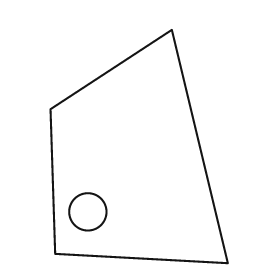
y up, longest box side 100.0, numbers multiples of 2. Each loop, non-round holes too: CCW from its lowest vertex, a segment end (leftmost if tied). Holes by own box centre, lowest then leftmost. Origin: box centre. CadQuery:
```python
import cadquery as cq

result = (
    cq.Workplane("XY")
    .moveTo(38.0, -50.0)
    .lineTo(14.0, 50.0)
    .lineTo(-38.0, 16.0)
    .lineTo(-36.0, -46.0)
    .close()
    .moveTo(-22.0, -28.0)
    .circle(8.0)
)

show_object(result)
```